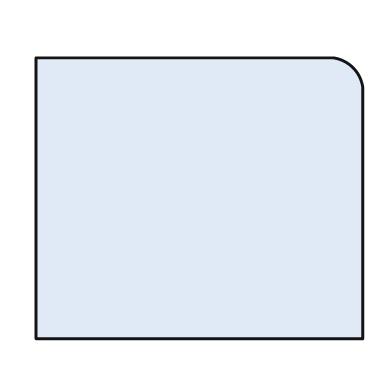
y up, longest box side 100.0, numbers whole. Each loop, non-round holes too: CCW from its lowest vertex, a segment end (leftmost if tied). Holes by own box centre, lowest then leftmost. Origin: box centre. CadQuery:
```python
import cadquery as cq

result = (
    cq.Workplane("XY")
    .moveTo(-50.0, -43.0)
    .lineTo(50.0, -43.0)
    .lineTo(50.0, 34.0)
    .threePointArc((47.0, 40.0), (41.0, 43.0))
    .lineTo(-50.0, 43.0)
    .close()
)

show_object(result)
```